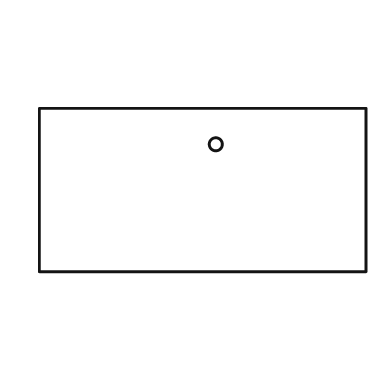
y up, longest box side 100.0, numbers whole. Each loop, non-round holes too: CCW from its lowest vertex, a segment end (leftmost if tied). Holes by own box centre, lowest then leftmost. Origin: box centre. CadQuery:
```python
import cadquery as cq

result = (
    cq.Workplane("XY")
    .moveTo(-50.0, -25.0)
    .lineTo(50.0, -25.0)
    .lineTo(50.0, 25.0)
    .lineTo(-50.0, 25.0)
    .close()
    .moveTo(4.0, 14.0)
    .circle(2.0)
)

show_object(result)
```